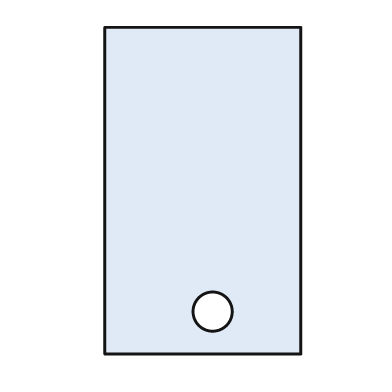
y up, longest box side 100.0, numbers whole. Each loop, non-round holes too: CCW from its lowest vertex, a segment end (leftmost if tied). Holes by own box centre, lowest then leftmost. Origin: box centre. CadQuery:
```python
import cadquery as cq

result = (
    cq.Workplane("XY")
    .moveTo(-30.0, -50.0)
    .lineTo(30.0, -50.0)
    .lineTo(30.0, 50.0)
    .lineTo(-30.0, 50.0)
    .close()
    .moveTo(3.0, -37.0)
    .circle(6.0)
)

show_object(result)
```